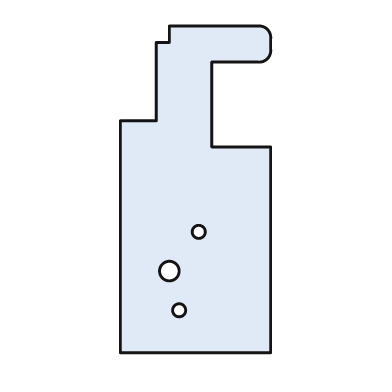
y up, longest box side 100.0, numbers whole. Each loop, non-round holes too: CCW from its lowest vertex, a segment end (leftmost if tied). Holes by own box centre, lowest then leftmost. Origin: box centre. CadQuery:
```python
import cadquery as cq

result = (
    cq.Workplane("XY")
    .moveTo(-23.0, -50.0)
    .lineTo(23.0, -50.0)
    .lineTo(23.0, 13.0)
    .lineTo(5.0, 13.0)
    .lineTo(5.0, 39.0)
    .lineTo(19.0, 39.0)
    .threePointArc((22.0, 40.0), (23.0, 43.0))
    .lineTo(23.0, 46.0)
    .threePointArc((22.0, 49.0), (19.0, 50.0))
    .lineTo(-8.0, 50.0)
    .lineTo(-8.0, 45.0)
    .lineTo(-12.0, 45.0)
    .lineTo(-12.0, 21.0)
    .lineTo(-23.0, 21.0)
    .close()
    .moveTo(-5.0, -37.0)
    .circle(2.0)
    .moveTo(-8.0, -25.0)
    .circle(3.0)
    .moveTo(1.0, -13.0)
    .circle(2.0)
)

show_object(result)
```